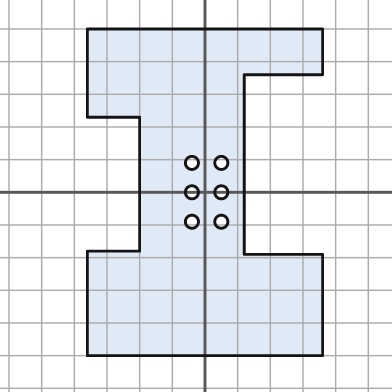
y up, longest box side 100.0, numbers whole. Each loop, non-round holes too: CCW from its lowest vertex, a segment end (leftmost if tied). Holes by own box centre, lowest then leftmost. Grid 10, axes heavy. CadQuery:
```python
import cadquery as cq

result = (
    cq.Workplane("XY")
    .moveTo(-36.0, -50.0)
    .lineTo(36.0, -50.0)
    .lineTo(36.0, -19.0)
    .lineTo(12.0, -19.0)
    .lineTo(12.0, 36.0)
    .lineTo(36.0, 36.0)
    .lineTo(36.0, 50.0)
    .lineTo(-36.0, 50.0)
    .lineTo(-36.0, 23.0)
    .lineTo(-20.0, 23.0)
    .lineTo(-20.0, -18.0)
    .lineTo(-36.0, -18.0)
    .close()
    .moveTo(-4.0, -9.0)
    .circle(2.0)
    .moveTo(5.0, -9.0)
    .circle(2.0)
    .moveTo(-4.0, 0.0)
    .circle(2.0)
    .moveTo(5.0, 0.0)
    .circle(2.0)
    .moveTo(-4.0, 9.0)
    .circle(2.0)
    .moveTo(5.0, 9.0)
    .circle(2.0)
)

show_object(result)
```